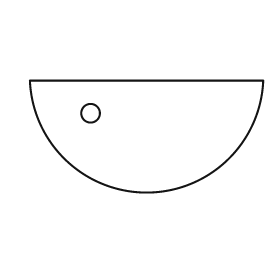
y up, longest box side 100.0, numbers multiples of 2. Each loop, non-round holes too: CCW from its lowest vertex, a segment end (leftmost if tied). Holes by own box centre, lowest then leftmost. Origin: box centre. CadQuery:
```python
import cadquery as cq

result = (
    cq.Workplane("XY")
    .moveTo(-50.0, 24.0)
    .threePointArc((0.0, -24.0), (50.0, 24.0))
    .close()
    .moveTo(-24.0, 10.0)
    .circle(4.0)
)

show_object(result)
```